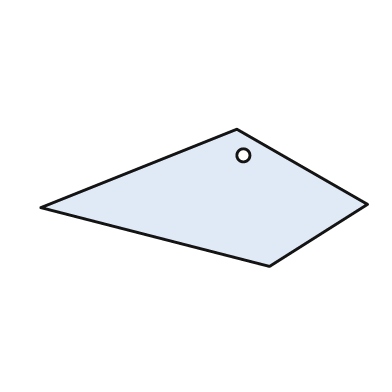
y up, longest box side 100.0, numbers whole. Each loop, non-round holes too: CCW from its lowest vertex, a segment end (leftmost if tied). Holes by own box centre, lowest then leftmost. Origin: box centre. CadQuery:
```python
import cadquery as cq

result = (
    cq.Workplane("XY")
    .moveTo(20.0, -21.0)
    .lineTo(50.0, -2.0)
    .lineTo(10.0, 21.0)
    .lineTo(-50.0, -3.0)
    .close()
    .moveTo(12.0, 13.0)
    .circle(2.0)
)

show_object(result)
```